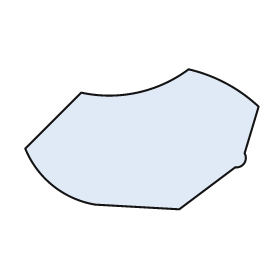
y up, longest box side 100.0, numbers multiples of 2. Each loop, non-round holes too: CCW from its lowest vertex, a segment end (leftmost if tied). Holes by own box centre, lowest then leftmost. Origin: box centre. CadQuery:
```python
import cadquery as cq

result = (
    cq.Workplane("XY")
    .moveTo(16.0, -30.0)
    .lineTo(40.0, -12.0)
    .threePointArc((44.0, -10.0), (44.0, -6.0))
    .lineTo(50.0, 14.0)
    .threePointArc((36.0, 24.0), (20.0, 30.0))
    .threePointArc((-2.0, 20.0), (-26.0, 20.0))
    .lineTo(-50.0, -4.0)
    .threePointArc((-38.0, -20.0), (-20.0, -28.0))
    .close()
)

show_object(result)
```